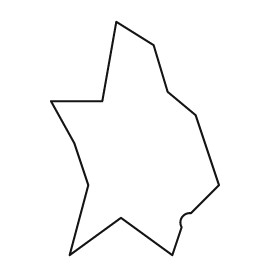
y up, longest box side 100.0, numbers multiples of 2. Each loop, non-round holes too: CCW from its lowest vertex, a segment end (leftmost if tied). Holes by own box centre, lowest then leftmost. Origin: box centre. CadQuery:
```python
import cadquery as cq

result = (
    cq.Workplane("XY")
    .moveTo(-28.0, -50.0)
    .lineTo(-6.0, -34.0)
    .lineTo(16.0, -50.0)
    .lineTo(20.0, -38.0)
    .threePointArc((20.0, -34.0), (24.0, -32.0))
    .lineTo(36.0, -20.0)
    .lineTo(26.0, 10.0)
    .lineTo(14.0, 20.0)
    .lineTo(8.0, 40.0)
    .lineTo(-8.0, 50.0)
    .lineTo(-14.0, 16.0)
    .lineTo(-36.0, 16.0)
    .lineTo(-26.0, -2.0)
    .lineTo(-20.0, -20.0)
    .close()
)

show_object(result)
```